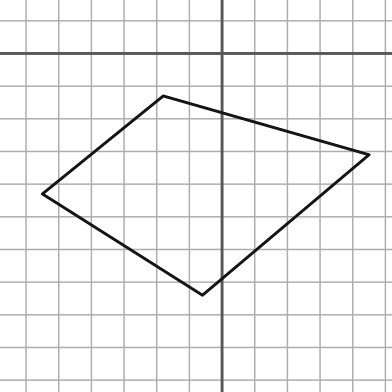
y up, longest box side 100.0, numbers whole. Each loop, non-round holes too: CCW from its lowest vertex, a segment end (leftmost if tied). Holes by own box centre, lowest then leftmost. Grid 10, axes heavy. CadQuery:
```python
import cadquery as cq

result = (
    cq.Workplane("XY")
    .moveTo(-6.0, -74.0)
    .lineTo(45.0, -31.0)
    .lineTo(-18.0, -13.0)
    .lineTo(-55.0, -43.0)
    .close()
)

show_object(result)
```